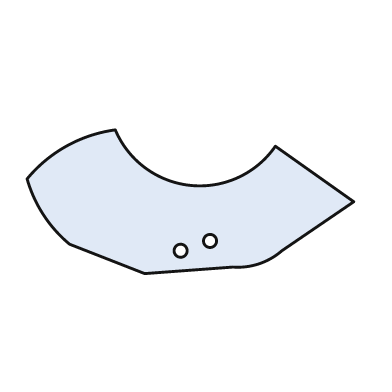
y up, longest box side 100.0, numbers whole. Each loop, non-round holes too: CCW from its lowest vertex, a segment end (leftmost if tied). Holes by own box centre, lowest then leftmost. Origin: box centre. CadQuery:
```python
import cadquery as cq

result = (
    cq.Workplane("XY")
    .moveTo(-14.0, -22.0)
    .lineTo(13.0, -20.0)
    .threePointArc((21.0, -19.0), (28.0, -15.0))
    .lineTo(50.0, 0.0)
    .lineTo(26.0, 17.0)
    .threePointArc((0.0, 5.0), (-23.0, 22.0))
    .threePointArc((-38.0, 17.0), (-50.0, 7.0))
    .threePointArc((-45.0, -4.0), (-37.0, -13.0))
    .close()
    .moveTo(-3.0, -15.0)
    .circle(2.0)
    .moveTo(6.0, -12.0)
    .circle(2.0)
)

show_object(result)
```